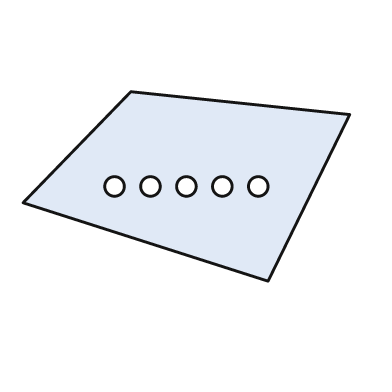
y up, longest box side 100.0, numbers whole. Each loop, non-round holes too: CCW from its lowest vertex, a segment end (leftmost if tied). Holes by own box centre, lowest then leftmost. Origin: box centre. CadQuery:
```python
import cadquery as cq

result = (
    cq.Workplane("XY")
    .moveTo(25.0, -29.0)
    .lineTo(50.0, 22.0)
    .lineTo(-17.0, 29.0)
    .lineTo(-50.0, -5.0)
    .close()
    .moveTo(-22.0, 0.0)
    .circle(3.0)
    .moveTo(-11.0, 0.0)
    .circle(3.0)
    .moveTo(0.0, 0.0)
    .circle(3.0)
    .moveTo(11.0, 0.0)
    .circle(3.0)
    .moveTo(22.0, 0.0)
    .circle(3.0)
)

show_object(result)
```